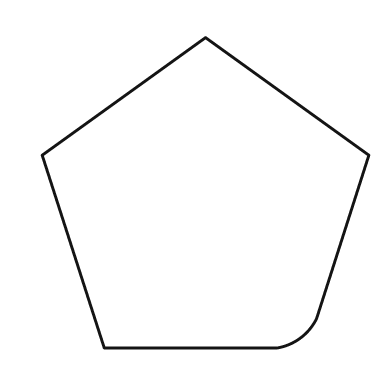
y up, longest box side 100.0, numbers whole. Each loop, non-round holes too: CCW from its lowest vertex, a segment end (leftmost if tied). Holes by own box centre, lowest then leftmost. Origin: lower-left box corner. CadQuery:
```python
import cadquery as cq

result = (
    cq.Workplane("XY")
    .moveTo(19.0, 0.0)
    .lineTo(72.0, 0.0)
    .threePointArc((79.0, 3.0), (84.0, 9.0))
    .lineTo(100.0, 59.0)
    .lineTo(50.0, 95.0)
    .lineTo(0.0, 59.0)
    .close()
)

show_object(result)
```